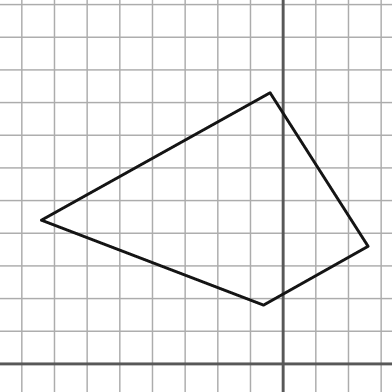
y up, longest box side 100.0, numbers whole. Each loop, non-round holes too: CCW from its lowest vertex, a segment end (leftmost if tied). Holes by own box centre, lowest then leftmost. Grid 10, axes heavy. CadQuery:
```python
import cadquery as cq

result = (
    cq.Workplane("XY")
    .moveTo(-6.0, 18.0)
    .lineTo(26.0, 36.0)
    .lineTo(-4.0, 83.0)
    .lineTo(-74.0, 44.0)
    .close()
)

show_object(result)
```